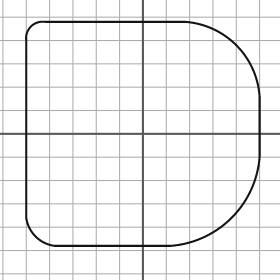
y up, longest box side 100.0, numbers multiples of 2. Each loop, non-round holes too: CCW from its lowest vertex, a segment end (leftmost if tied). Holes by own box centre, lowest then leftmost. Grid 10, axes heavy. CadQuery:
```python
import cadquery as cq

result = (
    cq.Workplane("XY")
    .moveTo(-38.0, -48.0)
    .lineTo(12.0, -48.0)
    .threePointArc((38.0, -36.0), (50.0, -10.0))
    .lineTo(50.0, 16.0)
    .threePointArc((40.0, 38.0), (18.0, 48.0))
    .lineTo(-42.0, 48.0)
    .threePointArc((-48.0, 46.0), (-50.0, 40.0))
    .lineTo(-50.0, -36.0)
    .threePointArc((-46.0, -44.0), (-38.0, -48.0))
    .close()
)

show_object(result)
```